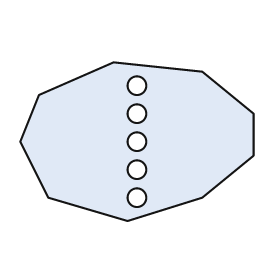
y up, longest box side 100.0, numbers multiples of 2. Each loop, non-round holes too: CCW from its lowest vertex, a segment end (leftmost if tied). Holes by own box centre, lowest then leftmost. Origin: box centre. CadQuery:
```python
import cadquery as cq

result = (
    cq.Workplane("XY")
    .moveTo(-4.0, -34.0)
    .lineTo(28.0, -24.0)
    .lineTo(50.0, -6.0)
    .lineTo(50.0, 12.0)
    .lineTo(28.0, 30.0)
    .lineTo(-10.0, 34.0)
    .lineTo(-42.0, 20.0)
    .lineTo(-50.0, 0.0)
    .lineTo(-38.0, -24.0)
    .close()
    .moveTo(0.0, -24.0)
    .circle(4.0)
    .moveTo(0.0, -12.0)
    .circle(4.0)
    .moveTo(0.0, 0.0)
    .circle(4.0)
    .moveTo(0.0, 12.0)
    .circle(4.0)
    .moveTo(0.0, 24.0)
    .circle(4.0)
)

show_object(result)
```